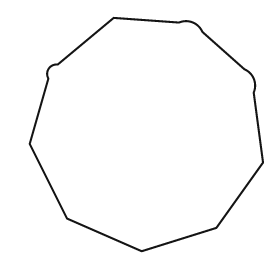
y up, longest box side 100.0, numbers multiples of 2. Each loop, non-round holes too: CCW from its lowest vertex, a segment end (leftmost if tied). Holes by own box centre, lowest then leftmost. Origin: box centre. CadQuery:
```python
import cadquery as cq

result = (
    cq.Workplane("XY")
    .moveTo(-2.0, -50.0)
    .lineTo(30.0, -40.0)
    .lineTo(50.0, -12.0)
    .lineTo(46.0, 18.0)
    .threePointArc((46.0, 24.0), (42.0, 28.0))
    .lineTo(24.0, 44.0)
    .threePointArc((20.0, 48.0), (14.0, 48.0))
    .lineTo(-14.0, 50.0)
    .lineTo(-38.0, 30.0)
    .threePointArc((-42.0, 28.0), (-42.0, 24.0))
    .lineTo(-50.0, -4.0)
    .lineTo(-34.0, -36.0)
    .close()
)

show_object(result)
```